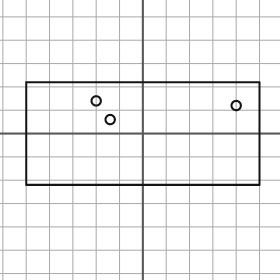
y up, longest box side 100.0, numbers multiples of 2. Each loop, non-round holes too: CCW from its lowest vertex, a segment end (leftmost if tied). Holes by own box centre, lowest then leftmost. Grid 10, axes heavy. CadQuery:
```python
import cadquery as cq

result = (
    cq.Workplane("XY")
    .moveTo(-50.0, -22.0)
    .lineTo(50.0, -22.0)
    .lineTo(50.0, 22.0)
    .lineTo(-50.0, 22.0)
    .close()
    .moveTo(-14.0, 6.0)
    .circle(2.0)
    .moveTo(40.0, 12.0)
    .circle(2.0)
    .moveTo(-20.0, 14.0)
    .circle(2.0)
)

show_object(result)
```